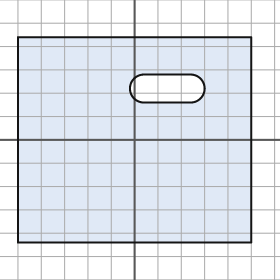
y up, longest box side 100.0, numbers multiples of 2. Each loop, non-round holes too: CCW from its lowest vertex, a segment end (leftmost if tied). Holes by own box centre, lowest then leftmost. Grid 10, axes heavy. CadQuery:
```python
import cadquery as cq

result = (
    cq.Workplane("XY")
    .moveTo(-50.0, -44.0)
    .lineTo(50.0, -44.0)
    .lineTo(50.0, 44.0)
    .lineTo(-50.0, 44.0)
    .close()
    .moveTo(4.0, 16.0)
    .lineTo(24.0, 16.0)
    .threePointArc((30.0, 22.0), (24.0, 28.0))
    .lineTo(4.0, 28.0)
    .threePointArc((-2.0, 22.0), (4.0, 16.0))
    .close()
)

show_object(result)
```